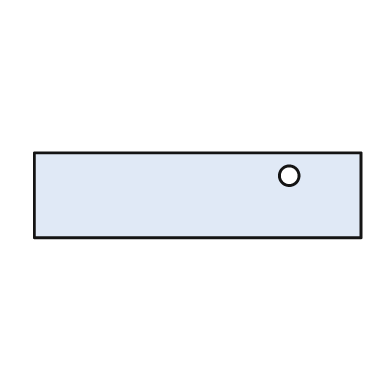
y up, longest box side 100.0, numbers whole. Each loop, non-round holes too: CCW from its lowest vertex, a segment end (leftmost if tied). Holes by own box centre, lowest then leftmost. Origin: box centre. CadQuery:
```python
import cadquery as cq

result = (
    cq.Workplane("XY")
    .moveTo(-50.0, -13.0)
    .lineTo(50.0, -13.0)
    .lineTo(50.0, 13.0)
    .lineTo(-50.0, 13.0)
    .close()
    .moveTo(28.0, 6.0)
    .circle(3.0)
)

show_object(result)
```